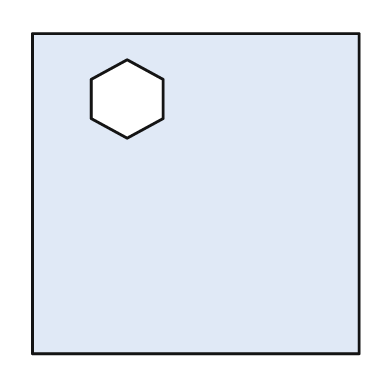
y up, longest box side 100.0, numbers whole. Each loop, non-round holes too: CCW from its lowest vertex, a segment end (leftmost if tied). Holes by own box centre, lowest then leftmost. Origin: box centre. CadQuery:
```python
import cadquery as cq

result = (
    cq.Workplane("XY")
    .moveTo(-50.0, -49.0)
    .lineTo(50.0, -49.0)
    .lineTo(50.0, 49.0)
    .lineTo(-50.0, 49.0)
    .close()
    .moveTo(-21.0, 17.0)
    .lineTo(-10.0, 23.0)
    .lineTo(-10.0, 35.0)
    .lineTo(-21.0, 41.0)
    .lineTo(-32.0, 35.0)
    .lineTo(-32.0, 23.0)
    .close()
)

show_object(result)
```